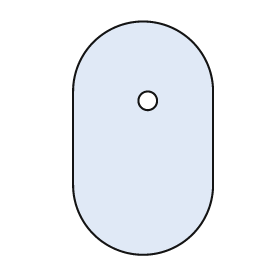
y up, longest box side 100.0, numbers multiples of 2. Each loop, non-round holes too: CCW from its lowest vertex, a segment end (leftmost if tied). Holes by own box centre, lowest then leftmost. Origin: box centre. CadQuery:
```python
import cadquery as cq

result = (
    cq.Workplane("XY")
    .moveTo(-30.0, -20.0)
    .threePointArc((0.0, -50.0), (30.0, -20.0))
    .lineTo(30.0, 20.0)
    .threePointArc((0.0, 50.0), (-30.0, 20.0))
    .close()
    .moveTo(2.0, 16.0)
    .circle(4.0)
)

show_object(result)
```